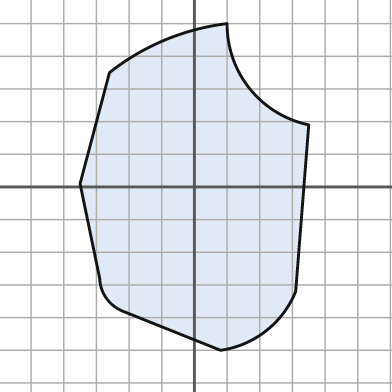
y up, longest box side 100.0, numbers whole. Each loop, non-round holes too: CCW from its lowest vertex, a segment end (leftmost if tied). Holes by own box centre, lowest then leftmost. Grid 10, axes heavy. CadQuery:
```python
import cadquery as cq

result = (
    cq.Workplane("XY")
    .moveTo(8.0, -50.0)
    .threePointArc((22.0, -44.0), (31.0, -32.0))
    .lineTo(35.0, 19.0)
    .threePointArc((17.0, 30.0), (10.0, 50.0))
    .threePointArc((-9.0, 45.0), (-26.0, 35.0))
    .lineTo(-35.0, 1.0)
    .lineTo(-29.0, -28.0)
    .threePointArc((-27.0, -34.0), (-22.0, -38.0))
    .close()
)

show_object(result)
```